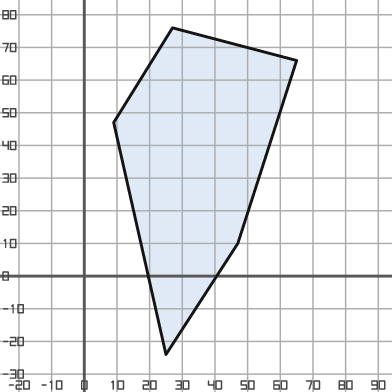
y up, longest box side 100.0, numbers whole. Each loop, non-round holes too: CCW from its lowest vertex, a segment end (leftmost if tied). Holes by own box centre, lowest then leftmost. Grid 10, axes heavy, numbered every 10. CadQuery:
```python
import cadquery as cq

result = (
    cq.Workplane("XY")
    .moveTo(25.0, -24.0)
    .lineTo(47.0, 10.0)
    .lineTo(65.0, 66.0)
    .lineTo(27.0, 76.0)
    .lineTo(9.0, 47.0)
    .close()
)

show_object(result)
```